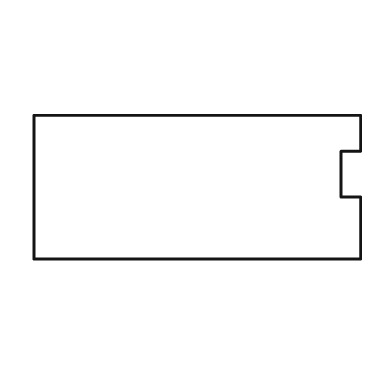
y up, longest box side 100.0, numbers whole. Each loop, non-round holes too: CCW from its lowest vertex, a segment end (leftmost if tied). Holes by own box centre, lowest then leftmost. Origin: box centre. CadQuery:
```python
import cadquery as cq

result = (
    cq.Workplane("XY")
    .moveTo(-50.0, -22.0)
    .lineTo(50.0, -22.0)
    .lineTo(50.0, -3.0)
    .lineTo(44.0, -3.0)
    .lineTo(44.0, 11.0)
    .lineTo(50.0, 11.0)
    .lineTo(50.0, 22.0)
    .lineTo(-50.0, 22.0)
    .close()
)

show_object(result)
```